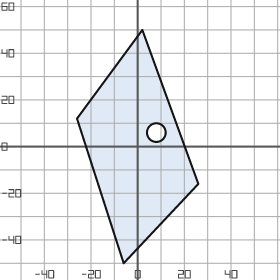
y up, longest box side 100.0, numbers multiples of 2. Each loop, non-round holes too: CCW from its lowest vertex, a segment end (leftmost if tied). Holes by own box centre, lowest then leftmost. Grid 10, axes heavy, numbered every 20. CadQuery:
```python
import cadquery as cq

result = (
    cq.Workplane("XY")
    .moveTo(-6.0, -50.0)
    .lineTo(26.0, -16.0)
    .lineTo(2.0, 50.0)
    .lineTo(-26.0, 12.0)
    .close()
    .moveTo(8.0, 6.0)
    .circle(4.0)
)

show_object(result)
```